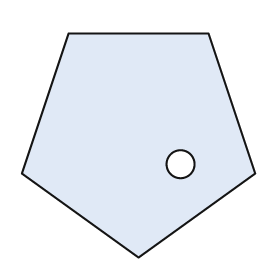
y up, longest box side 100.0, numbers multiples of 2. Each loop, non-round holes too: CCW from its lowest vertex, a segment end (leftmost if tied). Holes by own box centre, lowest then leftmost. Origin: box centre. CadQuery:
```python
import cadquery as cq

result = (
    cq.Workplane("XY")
    .moveTo(0.0, -48.0)
    .lineTo(50.0, -12.0)
    .lineTo(30.0, 48.0)
    .lineTo(-30.0, 48.0)
    .lineTo(-50.0, -12.0)
    .close()
    .moveTo(18.0, -8.0)
    .circle(6.0)
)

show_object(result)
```